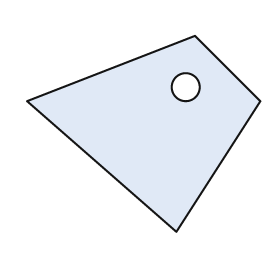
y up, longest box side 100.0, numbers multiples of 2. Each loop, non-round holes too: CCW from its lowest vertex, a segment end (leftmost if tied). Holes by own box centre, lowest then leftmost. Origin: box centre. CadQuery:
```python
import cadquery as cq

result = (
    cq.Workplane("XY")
    .moveTo(14.0, -42.0)
    .lineTo(50.0, 14.0)
    .lineTo(22.0, 42.0)
    .lineTo(-50.0, 14.0)
    .close()
    .moveTo(18.0, 20.0)
    .circle(6.0)
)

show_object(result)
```